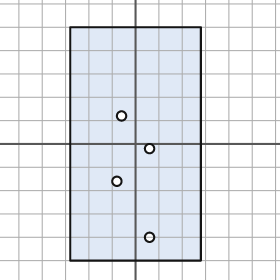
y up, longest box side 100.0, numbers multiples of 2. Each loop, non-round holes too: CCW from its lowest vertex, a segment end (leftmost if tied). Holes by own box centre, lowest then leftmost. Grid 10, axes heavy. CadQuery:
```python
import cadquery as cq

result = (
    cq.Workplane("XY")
    .moveTo(-28.0, -50.0)
    .lineTo(28.0, -50.0)
    .lineTo(28.0, 50.0)
    .lineTo(-28.0, 50.0)
    .close()
    .moveTo(6.0, -40.0)
    .circle(2.0)
    .moveTo(-8.0, -16.0)
    .circle(2.0)
    .moveTo(6.0, -2.0)
    .circle(2.0)
    .moveTo(-6.0, 12.0)
    .circle(2.0)
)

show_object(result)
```